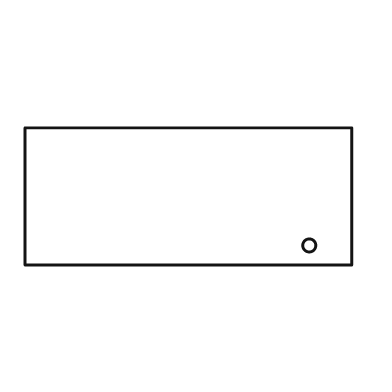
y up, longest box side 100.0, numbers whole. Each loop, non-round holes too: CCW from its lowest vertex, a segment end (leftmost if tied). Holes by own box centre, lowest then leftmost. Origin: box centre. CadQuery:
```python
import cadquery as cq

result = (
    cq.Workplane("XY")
    .moveTo(-50.0, -21.0)
    .lineTo(50.0, -21.0)
    .lineTo(50.0, 21.0)
    .lineTo(-50.0, 21.0)
    .close()
    .moveTo(37.0, -15.0)
    .circle(2.0)
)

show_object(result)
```